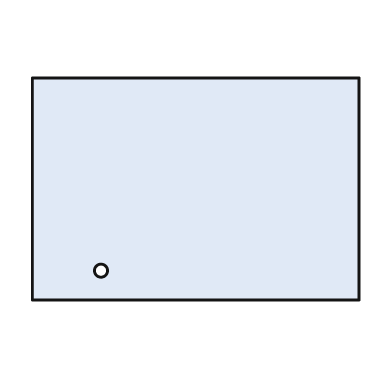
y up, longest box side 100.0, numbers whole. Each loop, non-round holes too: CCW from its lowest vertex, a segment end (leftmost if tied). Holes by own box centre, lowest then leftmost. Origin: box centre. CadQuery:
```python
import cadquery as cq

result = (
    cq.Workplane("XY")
    .moveTo(-50.0, -34.0)
    .lineTo(50.0, -34.0)
    .lineTo(50.0, 34.0)
    .lineTo(-50.0, 34.0)
    .close()
    .moveTo(-29.0, -25.0)
    .circle(2.0)
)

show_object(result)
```